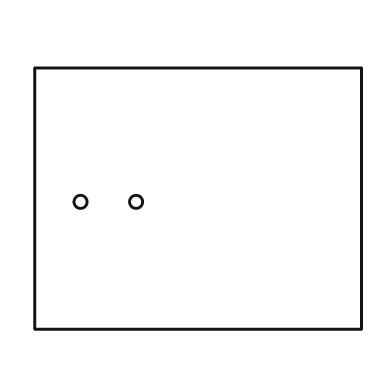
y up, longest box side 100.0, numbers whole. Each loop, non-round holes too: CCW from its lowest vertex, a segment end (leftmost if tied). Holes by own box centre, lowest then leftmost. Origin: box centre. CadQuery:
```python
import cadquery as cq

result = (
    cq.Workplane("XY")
    .moveTo(-50.0, -40.0)
    .lineTo(50.0, -40.0)
    .lineTo(50.0, 40.0)
    .lineTo(-50.0, 40.0)
    .close()
    .moveTo(-36.0, -1.0)
    .circle(2.0)
    .moveTo(-19.0, -1.0)
    .circle(2.0)
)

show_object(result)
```